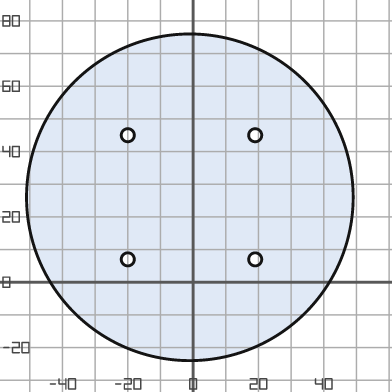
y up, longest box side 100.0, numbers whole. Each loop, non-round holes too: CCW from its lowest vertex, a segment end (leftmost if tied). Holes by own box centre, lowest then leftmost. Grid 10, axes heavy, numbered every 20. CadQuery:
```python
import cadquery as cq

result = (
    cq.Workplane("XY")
    .moveTo(-1.0, 26.0)
    .circle(50.0)
    .moveTo(-20.0, 7.0)
    .circle(2.0)
    .moveTo(19.0, 7.0)
    .circle(2.0)
    .moveTo(-20.0, 45.0)
    .circle(2.0)
    .moveTo(19.0, 45.0)
    .circle(2.0)
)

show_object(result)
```